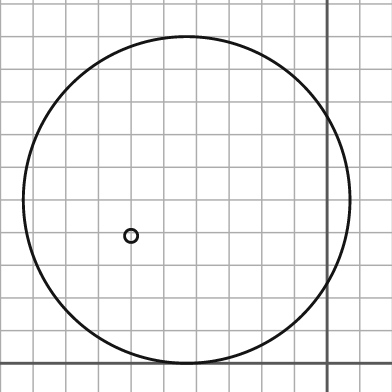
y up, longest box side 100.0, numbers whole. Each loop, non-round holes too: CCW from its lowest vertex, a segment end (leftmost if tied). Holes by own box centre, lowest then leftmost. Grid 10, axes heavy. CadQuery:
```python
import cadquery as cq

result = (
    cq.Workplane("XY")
    .moveTo(-43.0, 50.0)
    .circle(50.0)
    .moveTo(-60.0, 39.0)
    .circle(2.0)
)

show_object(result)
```